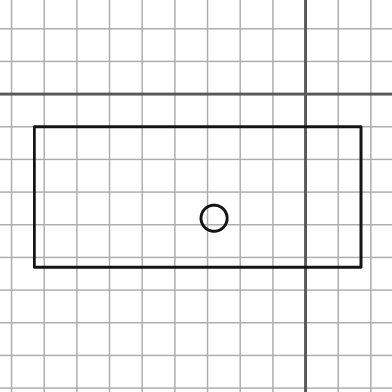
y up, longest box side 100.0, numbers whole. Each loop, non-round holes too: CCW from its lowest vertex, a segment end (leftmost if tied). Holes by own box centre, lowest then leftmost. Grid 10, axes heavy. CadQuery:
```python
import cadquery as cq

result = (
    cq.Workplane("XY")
    .moveTo(-83.0, -53.0)
    .lineTo(17.0, -53.0)
    .lineTo(17.0, -10.0)
    .lineTo(-83.0, -10.0)
    .close()
    .moveTo(-28.0, -38.0)
    .circle(4.0)
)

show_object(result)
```